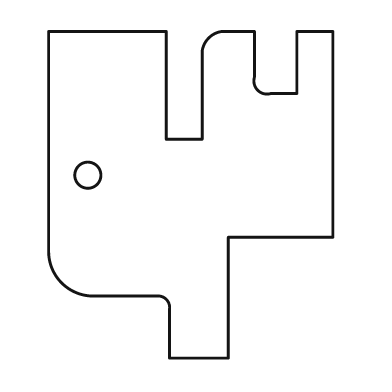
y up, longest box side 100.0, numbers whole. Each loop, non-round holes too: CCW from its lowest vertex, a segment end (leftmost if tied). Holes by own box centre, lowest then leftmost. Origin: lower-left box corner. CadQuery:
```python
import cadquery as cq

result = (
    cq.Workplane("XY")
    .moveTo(37.0, 0.0)
    .lineTo(55.0, 0.0)
    .lineTo(55.0, 37.0)
    .lineTo(87.0, 37.0)
    .lineTo(87.0, 100.0)
    .lineTo(76.0, 100.0)
    .lineTo(76.0, 81.0)
    .lineTo(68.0, 81.0)
    .threePointArc((64.0, 82.0), (63.0, 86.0))
    .lineTo(63.0, 100.0)
    .lineTo(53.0, 100.0)
    .threePointArc((49.0, 98.0), (47.0, 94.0))
    .lineTo(47.0, 67.0)
    .lineTo(36.0, 67.0)
    .lineTo(36.0, 100.0)
    .lineTo(0.0, 100.0)
    .lineTo(0.0, 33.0)
    .threePointArc((4.0, 23.0), (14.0, 19.0))
    .lineTo(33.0, 19.0)
    .threePointArc((36.0, 18.0), (37.0, 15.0))
    .close()
    .moveTo(12.0, 56.0)
    .circle(4.0)
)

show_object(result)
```